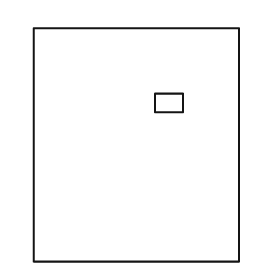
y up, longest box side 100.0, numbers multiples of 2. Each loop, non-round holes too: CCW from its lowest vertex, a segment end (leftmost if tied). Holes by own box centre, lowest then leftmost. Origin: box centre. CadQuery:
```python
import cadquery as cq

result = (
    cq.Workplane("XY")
    .moveTo(-44.0, -50.0)
    .lineTo(44.0, -50.0)
    .lineTo(44.0, 50.0)
    .lineTo(-44.0, 50.0)
    .close()
    .moveTo(8.0, 14.0)
    .lineTo(20.0, 14.0)
    .lineTo(20.0, 22.0)
    .lineTo(8.0, 22.0)
    .close()
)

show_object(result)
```